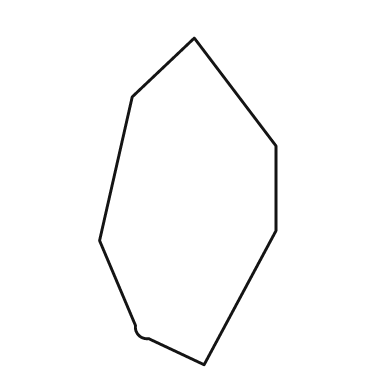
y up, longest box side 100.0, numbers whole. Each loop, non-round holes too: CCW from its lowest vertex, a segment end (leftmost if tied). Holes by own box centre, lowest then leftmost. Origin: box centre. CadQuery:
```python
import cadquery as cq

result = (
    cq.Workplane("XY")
    .moveTo(5.0, -50.0)
    .lineTo(27.0, -9.0)
    .lineTo(27.0, 17.0)
    .lineTo(2.0, 50.0)
    .lineTo(-17.0, 32.0)
    .lineTo(-27.0, -12.0)
    .lineTo(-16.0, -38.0)
    .threePointArc((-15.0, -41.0), (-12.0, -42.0))
    .close()
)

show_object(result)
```